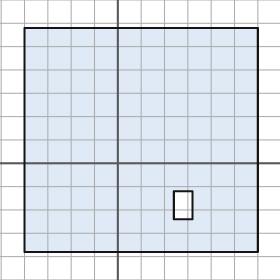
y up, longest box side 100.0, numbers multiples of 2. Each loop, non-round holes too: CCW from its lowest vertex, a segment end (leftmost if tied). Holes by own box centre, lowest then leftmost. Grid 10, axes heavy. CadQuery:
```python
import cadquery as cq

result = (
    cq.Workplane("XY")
    .moveTo(-40.0, -38.0)
    .lineTo(60.0, -38.0)
    .lineTo(60.0, 58.0)
    .lineTo(-40.0, 58.0)
    .close()
    .moveTo(24.0, -24.0)
    .lineTo(32.0, -24.0)
    .lineTo(32.0, -12.0)
    .lineTo(24.0, -12.0)
    .close()
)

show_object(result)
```